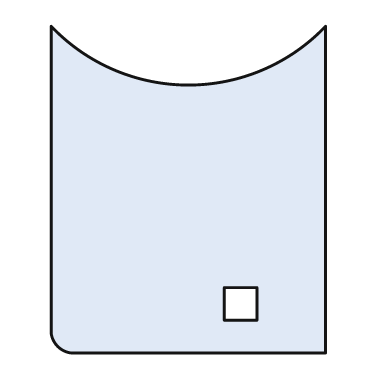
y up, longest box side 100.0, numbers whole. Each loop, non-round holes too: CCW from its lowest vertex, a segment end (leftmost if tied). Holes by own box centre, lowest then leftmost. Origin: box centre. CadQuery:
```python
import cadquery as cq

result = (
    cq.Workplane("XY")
    .moveTo(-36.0, -50.0)
    .lineTo(42.0, -50.0)
    .lineTo(42.0, 50.0)
    .threePointArc((0.0, 32.0), (-42.0, 50.0))
    .lineTo(-42.0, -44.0)
    .threePointArc((-40.0, -48.0), (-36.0, -50.0))
    .close()
    .moveTo(11.0, -40.0)
    .lineTo(21.0, -40.0)
    .lineTo(21.0, -30.0)
    .lineTo(11.0, -30.0)
    .close()
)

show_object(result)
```